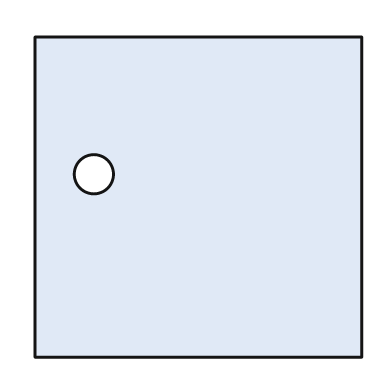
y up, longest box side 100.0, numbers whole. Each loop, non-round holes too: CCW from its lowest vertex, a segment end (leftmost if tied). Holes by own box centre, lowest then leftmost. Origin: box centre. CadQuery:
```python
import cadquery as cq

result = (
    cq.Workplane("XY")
    .moveTo(-50.0, -49.0)
    .lineTo(50.0, -49.0)
    .lineTo(50.0, 49.0)
    .lineTo(-50.0, 49.0)
    .close()
    .moveTo(-32.0, 7.0)
    .circle(6.0)
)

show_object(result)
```